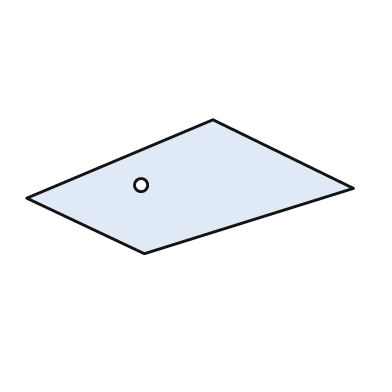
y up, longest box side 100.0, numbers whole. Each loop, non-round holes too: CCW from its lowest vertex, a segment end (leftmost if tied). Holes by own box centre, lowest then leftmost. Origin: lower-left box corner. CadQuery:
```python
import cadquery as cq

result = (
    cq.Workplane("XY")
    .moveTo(36.0, 0.0)
    .lineTo(100.0, 20.0)
    .lineTo(57.0, 41.0)
    .lineTo(0.0, 17.0)
    .close()
    .moveTo(35.0, 21.0)
    .circle(2.0)
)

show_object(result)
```